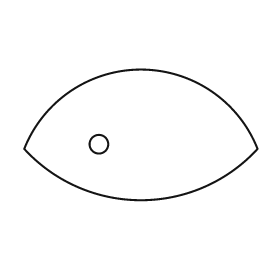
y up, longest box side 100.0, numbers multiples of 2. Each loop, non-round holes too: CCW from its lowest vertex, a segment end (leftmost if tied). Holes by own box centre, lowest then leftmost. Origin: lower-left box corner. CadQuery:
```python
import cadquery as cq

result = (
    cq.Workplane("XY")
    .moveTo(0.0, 22.0)
    .threePointArc((50.0, 0.0), (100.0, 22.0))
    .threePointArc((50.0, 56.0), (0.0, 22.0))
    .close()
    .moveTo(32.0, 24.0)
    .circle(4.0)
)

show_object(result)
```